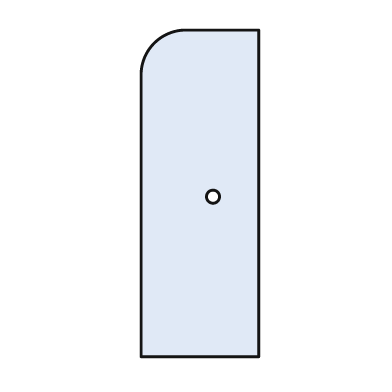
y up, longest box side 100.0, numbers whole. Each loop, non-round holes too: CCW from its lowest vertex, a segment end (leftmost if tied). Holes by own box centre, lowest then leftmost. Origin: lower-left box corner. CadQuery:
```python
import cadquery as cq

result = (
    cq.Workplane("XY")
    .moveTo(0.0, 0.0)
    .lineTo(36.0, 0.0)
    .lineTo(36.0, 100.0)
    .lineTo(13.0, 100.0)
    .threePointArc((4.0, 96.0), (0.0, 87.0))
    .close()
    .moveTo(22.0, 49.0)
    .circle(2.0)
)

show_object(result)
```